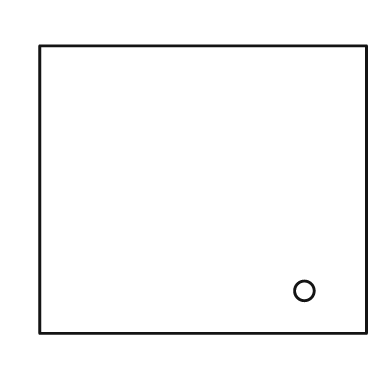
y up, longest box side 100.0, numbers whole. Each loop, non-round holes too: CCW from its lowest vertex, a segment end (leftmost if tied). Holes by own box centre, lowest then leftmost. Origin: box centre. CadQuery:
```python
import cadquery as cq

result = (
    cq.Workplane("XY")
    .moveTo(-50.0, -44.0)
    .lineTo(50.0, -44.0)
    .lineTo(50.0, 44.0)
    .lineTo(-50.0, 44.0)
    .close()
    .moveTo(31.0, -31.0)
    .circle(3.0)
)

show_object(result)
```